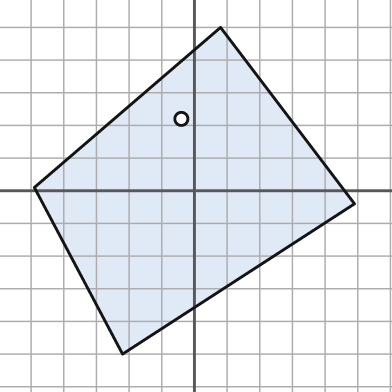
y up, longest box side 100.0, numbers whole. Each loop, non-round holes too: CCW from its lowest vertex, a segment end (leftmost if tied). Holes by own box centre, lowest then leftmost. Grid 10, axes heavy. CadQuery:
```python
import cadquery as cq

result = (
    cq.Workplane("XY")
    .moveTo(-22.0, -50.0)
    .lineTo(49.0, -4.0)
    .lineTo(8.0, 50.0)
    .lineTo(-49.0, 1.0)
    .close()
    .moveTo(-4.0, 22.0)
    .circle(2.0)
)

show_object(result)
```